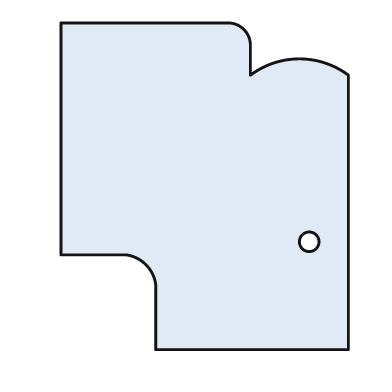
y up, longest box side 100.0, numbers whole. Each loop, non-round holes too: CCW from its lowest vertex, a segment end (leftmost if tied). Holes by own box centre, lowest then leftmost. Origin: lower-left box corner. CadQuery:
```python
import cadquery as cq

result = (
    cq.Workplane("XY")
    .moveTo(29.0, 0.0)
    .lineTo(88.0, 0.0)
    .lineTo(88.0, 84.0)
    .threePointArc((73.0, 89.0), (58.0, 84.0))
    .lineTo(58.0, 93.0)
    .threePointArc((56.0, 98.0), (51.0, 100.0))
    .lineTo(0.0, 100.0)
    .lineTo(0.0, 29.0)
    .lineTo(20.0, 29.0)
    .threePointArc((26.0, 26.0), (29.0, 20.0))
    .close()
    .moveTo(76.0, 33.0)
    .circle(3.0)
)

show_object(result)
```